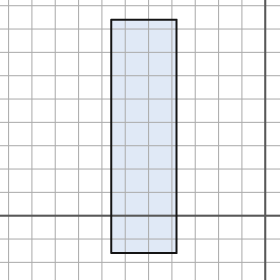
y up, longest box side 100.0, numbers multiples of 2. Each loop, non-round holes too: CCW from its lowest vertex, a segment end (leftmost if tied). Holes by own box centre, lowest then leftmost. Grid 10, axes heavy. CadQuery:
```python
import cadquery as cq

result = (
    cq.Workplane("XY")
    .moveTo(-66.0, -16.0)
    .lineTo(-38.0, -16.0)
    .lineTo(-38.0, 84.0)
    .lineTo(-66.0, 84.0)
    .close()
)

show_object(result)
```